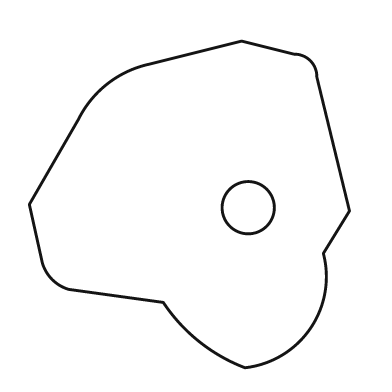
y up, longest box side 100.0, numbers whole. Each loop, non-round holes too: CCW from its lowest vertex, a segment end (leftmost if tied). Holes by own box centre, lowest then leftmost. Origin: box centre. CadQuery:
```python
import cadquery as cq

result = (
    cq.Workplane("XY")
    .moveTo(17.0, -50.0)
    .threePointArc((37.0, -38.0), (41.0, -15.0))
    .lineTo(49.0, -2.0)
    .lineTo(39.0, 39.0)
    .threePointArc((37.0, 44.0), (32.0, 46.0))
    .lineTo(16.0, 50.0)
    .lineTo(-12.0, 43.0)
    .threePointArc((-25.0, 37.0), (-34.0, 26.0))
    .lineTo(-49.0, 0.0)
    .lineTo(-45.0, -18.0)
    .threePointArc((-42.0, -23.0), (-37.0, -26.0))
    .lineTo(-8.0, -30.0)
    .threePointArc((3.0, -42.0), (17.0, -50.0))
    .close()
    .moveTo(18.0, -1.0)
    .circle(8.0)
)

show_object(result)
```